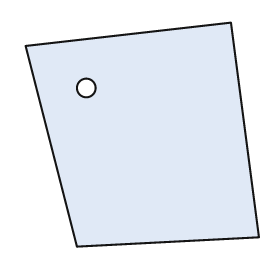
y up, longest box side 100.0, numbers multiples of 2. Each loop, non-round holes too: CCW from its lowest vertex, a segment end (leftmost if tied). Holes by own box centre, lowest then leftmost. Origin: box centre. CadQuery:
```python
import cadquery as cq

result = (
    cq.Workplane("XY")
    .moveTo(-28.0, -48.0)
    .lineTo(50.0, -44.0)
    .lineTo(38.0, 48.0)
    .lineTo(-50.0, 38.0)
    .close()
    .moveTo(-24.0, 20.0)
    .circle(4.0)
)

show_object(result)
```